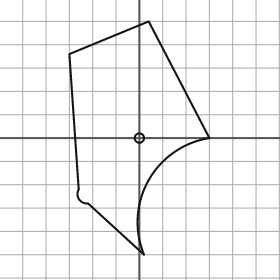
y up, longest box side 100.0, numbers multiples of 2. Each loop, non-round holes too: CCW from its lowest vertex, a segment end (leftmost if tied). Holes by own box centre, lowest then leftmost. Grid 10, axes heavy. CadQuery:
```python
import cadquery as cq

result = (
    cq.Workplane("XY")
    .moveTo(2.0, -50.0)
    .threePointArc((4.0, -18.0), (30.0, 0.0))
    .lineTo(4.0, 50.0)
    .lineTo(-30.0, 36.0)
    .lineTo(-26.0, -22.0)
    .threePointArc((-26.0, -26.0), (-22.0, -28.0))
    .close()
    .moveTo(0.0, 0.0)
    .circle(2.0)
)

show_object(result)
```